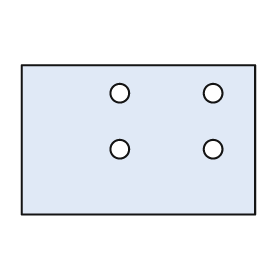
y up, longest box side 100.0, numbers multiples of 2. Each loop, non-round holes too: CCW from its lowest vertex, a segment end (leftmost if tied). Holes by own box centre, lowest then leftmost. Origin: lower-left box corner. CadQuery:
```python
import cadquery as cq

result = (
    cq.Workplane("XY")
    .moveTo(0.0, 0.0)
    .lineTo(100.0, 0.0)
    .lineTo(100.0, 64.0)
    .lineTo(0.0, 64.0)
    .close()
    .moveTo(42.0, 28.0)
    .circle(4.0)
    .moveTo(82.0, 28.0)
    .circle(4.0)
    .moveTo(42.0, 52.0)
    .circle(4.0)
    .moveTo(82.0, 52.0)
    .circle(4.0)
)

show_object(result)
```